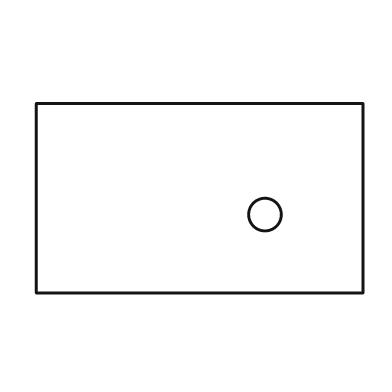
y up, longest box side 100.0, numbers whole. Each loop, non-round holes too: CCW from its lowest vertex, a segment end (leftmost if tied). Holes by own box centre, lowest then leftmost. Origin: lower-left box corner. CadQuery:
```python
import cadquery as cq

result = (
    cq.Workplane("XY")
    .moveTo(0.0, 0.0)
    .lineTo(100.0, 0.0)
    .lineTo(100.0, 58.0)
    .lineTo(0.0, 58.0)
    .close()
    .moveTo(70.0, 24.0)
    .circle(5.0)
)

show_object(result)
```